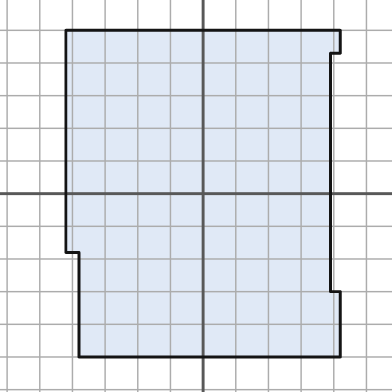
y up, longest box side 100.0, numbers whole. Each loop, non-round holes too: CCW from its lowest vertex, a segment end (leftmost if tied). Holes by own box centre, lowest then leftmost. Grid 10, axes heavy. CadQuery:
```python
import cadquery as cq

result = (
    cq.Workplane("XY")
    .moveTo(-38.0, -50.0)
    .lineTo(42.0, -50.0)
    .lineTo(42.0, -30.0)
    .lineTo(39.0, -30.0)
    .lineTo(39.0, 43.0)
    .lineTo(42.0, 43.0)
    .lineTo(42.0, 50.0)
    .lineTo(-42.0, 50.0)
    .lineTo(-42.0, -18.0)
    .lineTo(-38.0, -18.0)
    .close()
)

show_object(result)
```